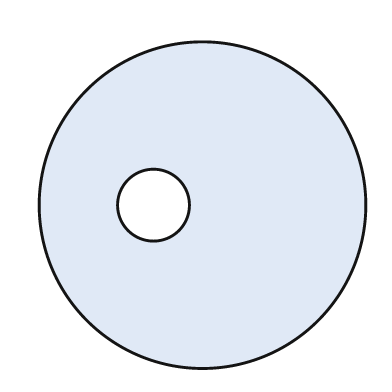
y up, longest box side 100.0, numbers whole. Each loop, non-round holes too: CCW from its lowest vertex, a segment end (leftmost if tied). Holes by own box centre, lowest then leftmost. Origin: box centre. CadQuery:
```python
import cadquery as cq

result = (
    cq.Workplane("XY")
    .moveTo(0.0, 0.0)
    .circle(50.0)
    .moveTo(-15.0, 0.0)
    .circle(11.0)
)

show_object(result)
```